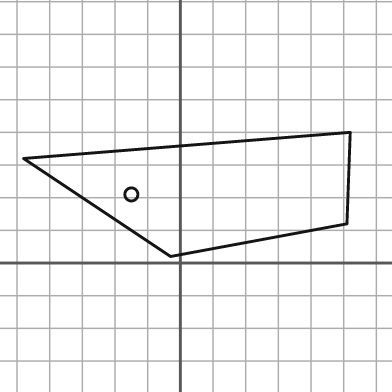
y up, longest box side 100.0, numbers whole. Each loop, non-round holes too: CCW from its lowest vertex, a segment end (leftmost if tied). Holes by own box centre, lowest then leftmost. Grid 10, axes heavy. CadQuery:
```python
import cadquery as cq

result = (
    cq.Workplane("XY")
    .moveTo(-3.0, 2.0)
    .lineTo(51.0, 12.0)
    .lineTo(52.0, 40.0)
    .lineTo(-48.0, 32.0)
    .close()
    .moveTo(-15.0, 21.0)
    .circle(2.0)
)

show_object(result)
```